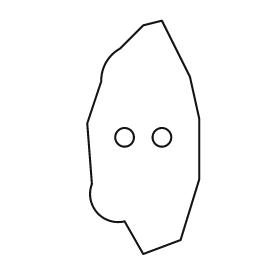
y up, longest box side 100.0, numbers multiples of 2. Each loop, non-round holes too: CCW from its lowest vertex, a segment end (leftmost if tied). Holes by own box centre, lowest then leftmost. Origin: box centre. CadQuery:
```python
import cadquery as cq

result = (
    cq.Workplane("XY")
    .moveTo(0.0, -50.0)
    .lineTo(16.0, -44.0)
    .lineTo(24.0, -18.0)
    .lineTo(24.0, 8.0)
    .lineTo(20.0, 26.0)
    .lineTo(8.0, 50.0)
    .lineTo(0.0, 48.0)
    .lineTo(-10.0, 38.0)
    .threePointArc((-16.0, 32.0), (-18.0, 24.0))
    .lineTo(-24.0, 6.0)
    .lineTo(-22.0, -20.0)
    .threePointArc((-20.0, -32.0), (-8.0, -36.0))
    .close()
    .moveTo(-8.0, 0.0)
    .circle(4.0)
    .moveTo(8.0, 0.0)
    .circle(4.0)
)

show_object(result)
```